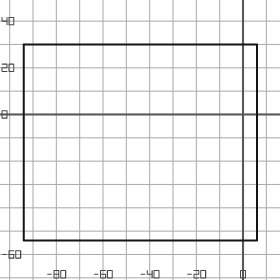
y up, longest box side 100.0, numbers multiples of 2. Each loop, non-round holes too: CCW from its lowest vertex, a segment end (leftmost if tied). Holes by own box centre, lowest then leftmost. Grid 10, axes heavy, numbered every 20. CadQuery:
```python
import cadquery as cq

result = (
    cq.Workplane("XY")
    .moveTo(-94.0, -54.0)
    .lineTo(6.0, -54.0)
    .lineTo(6.0, 30.0)
    .lineTo(-94.0, 30.0)
    .close()
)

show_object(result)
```